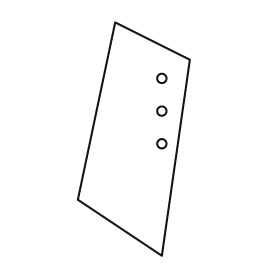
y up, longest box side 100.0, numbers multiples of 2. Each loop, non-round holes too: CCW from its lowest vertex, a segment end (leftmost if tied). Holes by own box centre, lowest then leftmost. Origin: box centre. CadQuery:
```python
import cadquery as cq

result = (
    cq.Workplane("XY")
    .moveTo(12.0, -50.0)
    .lineTo(24.0, 34.0)
    .lineTo(-8.0, 50.0)
    .lineTo(-24.0, -26.0)
    .close()
    .moveTo(12.0, -2.0)
    .circle(2.0)
    .moveTo(12.0, 12.0)
    .circle(2.0)
    .moveTo(12.0, 26.0)
    .circle(2.0)
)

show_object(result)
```